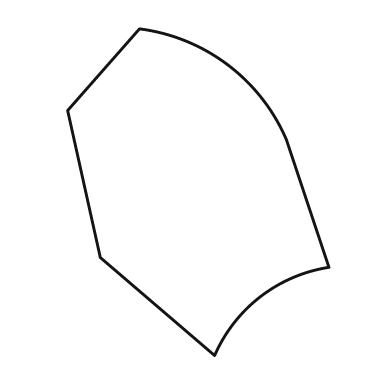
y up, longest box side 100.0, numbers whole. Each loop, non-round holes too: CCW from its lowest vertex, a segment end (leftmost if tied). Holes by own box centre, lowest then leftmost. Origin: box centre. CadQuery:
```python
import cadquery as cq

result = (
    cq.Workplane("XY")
    .moveTo(5.0, -50.0)
    .threePointArc((19.0, -32.0), (40.0, -23.0))
    .lineTo(27.0, 16.0)
    .threePointArc((9.0, 39.0), (-18.0, 50.0))
    .lineTo(-40.0, 25.0)
    .lineTo(-30.0, -20.0)
    .close()
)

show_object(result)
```